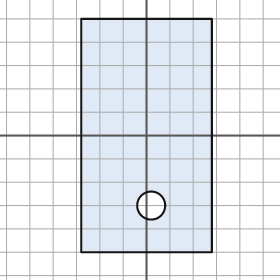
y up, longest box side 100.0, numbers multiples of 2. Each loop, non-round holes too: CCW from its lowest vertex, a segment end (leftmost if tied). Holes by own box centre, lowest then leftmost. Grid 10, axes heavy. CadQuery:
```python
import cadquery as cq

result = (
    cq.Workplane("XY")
    .moveTo(-28.0, -50.0)
    .lineTo(28.0, -50.0)
    .lineTo(28.0, 50.0)
    .lineTo(-28.0, 50.0)
    .close()
    .moveTo(2.0, -30.0)
    .circle(6.0)
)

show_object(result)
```